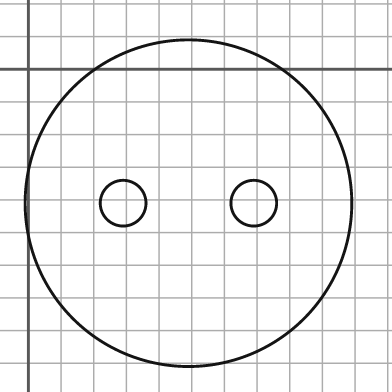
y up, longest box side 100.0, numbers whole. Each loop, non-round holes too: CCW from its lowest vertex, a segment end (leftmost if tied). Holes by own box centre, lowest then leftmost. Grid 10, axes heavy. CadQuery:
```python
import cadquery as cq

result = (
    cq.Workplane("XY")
    .moveTo(49.0, -41.0)
    .circle(50.0)
    .moveTo(29.0, -41.0)
    .circle(7.0)
    .moveTo(69.0, -41.0)
    .circle(7.0)
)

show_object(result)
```